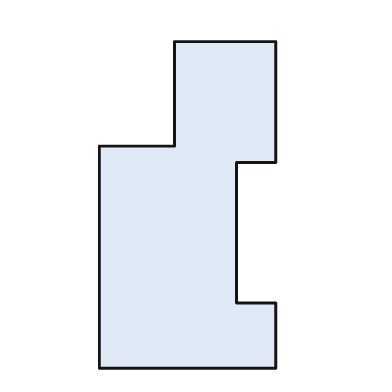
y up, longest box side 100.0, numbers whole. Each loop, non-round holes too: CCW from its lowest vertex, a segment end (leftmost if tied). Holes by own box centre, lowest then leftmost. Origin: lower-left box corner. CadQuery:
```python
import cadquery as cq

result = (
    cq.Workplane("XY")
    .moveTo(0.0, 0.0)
    .lineTo(54.0, 0.0)
    .lineTo(54.0, 20.0)
    .lineTo(42.0, 20.0)
    .lineTo(42.0, 63.0)
    .lineTo(54.0, 63.0)
    .lineTo(54.0, 100.0)
    .lineTo(23.0, 100.0)
    .lineTo(23.0, 68.0)
    .lineTo(0.0, 68.0)
    .close()
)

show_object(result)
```